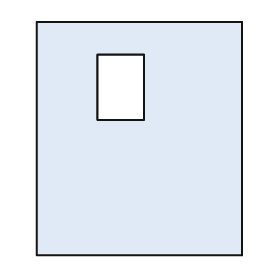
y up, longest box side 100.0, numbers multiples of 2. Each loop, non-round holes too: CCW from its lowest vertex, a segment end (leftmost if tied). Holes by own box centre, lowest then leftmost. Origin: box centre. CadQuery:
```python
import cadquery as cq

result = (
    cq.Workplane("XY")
    .moveTo(-44.0, -50.0)
    .lineTo(44.0, -50.0)
    .lineTo(44.0, 50.0)
    .lineTo(-44.0, 50.0)
    .close()
    .moveTo(-18.0, 8.0)
    .lineTo(2.0, 8.0)
    .lineTo(2.0, 36.0)
    .lineTo(-18.0, 36.0)
    .close()
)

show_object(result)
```